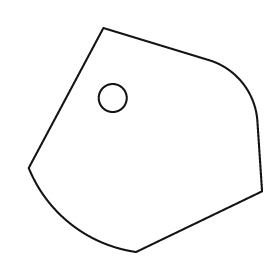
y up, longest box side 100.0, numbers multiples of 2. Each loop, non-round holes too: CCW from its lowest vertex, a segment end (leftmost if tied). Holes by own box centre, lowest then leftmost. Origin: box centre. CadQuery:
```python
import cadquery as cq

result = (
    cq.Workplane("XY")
    .moveTo(-4.0, -48.0)
    .lineTo(50.0, -22.0)
    .lineTo(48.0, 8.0)
    .threePointArc((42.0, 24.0), (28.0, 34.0))
    .lineTo(-18.0, 48.0)
    .lineTo(-50.0, -12.0)
    .threePointArc((-32.0, -36.0), (-4.0, -48.0))
    .close()
    .moveTo(-14.0, 18.0)
    .circle(6.0)
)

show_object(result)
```